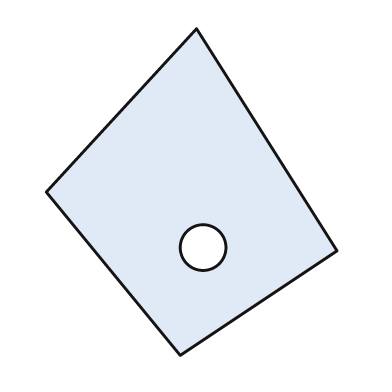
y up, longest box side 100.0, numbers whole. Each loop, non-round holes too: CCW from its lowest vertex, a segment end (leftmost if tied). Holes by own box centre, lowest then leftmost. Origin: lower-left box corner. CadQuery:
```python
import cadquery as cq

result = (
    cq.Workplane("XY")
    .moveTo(41.0, 0.0)
    .lineTo(89.0, 32.0)
    .lineTo(46.0, 100.0)
    .lineTo(0.0, 50.0)
    .close()
    .moveTo(48.0, 33.0)
    .circle(7.0)
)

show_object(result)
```